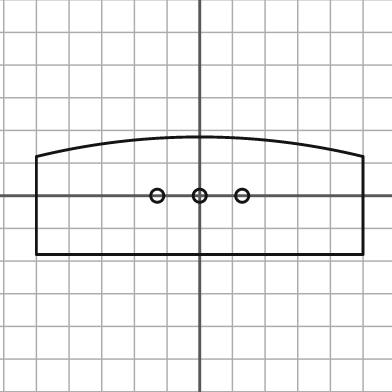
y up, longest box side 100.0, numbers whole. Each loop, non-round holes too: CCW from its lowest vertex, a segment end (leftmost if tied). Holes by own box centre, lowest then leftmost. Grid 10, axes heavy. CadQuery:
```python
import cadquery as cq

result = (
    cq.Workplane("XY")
    .moveTo(-50.0, -18.0)
    .lineTo(50.0, -18.0)
    .lineTo(50.0, 12.0)
    .threePointArc((0.0, 18.0), (-50.0, 12.0))
    .close()
    .moveTo(-13.0, 0.0)
    .circle(2.0)
    .moveTo(0.0, 0.0)
    .circle(2.0)
    .moveTo(13.0, 0.0)
    .circle(2.0)
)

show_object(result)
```